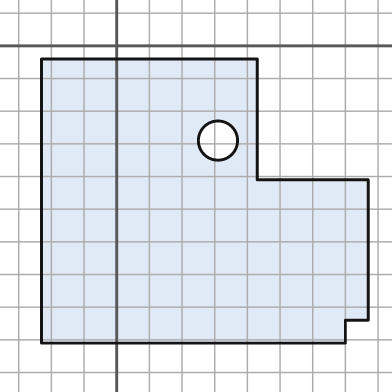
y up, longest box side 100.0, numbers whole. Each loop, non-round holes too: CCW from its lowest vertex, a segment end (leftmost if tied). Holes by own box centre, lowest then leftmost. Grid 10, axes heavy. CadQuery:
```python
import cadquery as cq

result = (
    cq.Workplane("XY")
    .moveTo(-23.0, -91.0)
    .lineTo(70.0, -91.0)
    .lineTo(70.0, -84.0)
    .lineTo(77.0, -84.0)
    .lineTo(77.0, -41.0)
    .lineTo(43.0, -41.0)
    .lineTo(43.0, -4.0)
    .lineTo(-23.0, -4.0)
    .close()
    .moveTo(31.0, -29.0)
    .circle(6.0)
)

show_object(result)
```